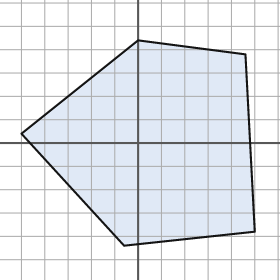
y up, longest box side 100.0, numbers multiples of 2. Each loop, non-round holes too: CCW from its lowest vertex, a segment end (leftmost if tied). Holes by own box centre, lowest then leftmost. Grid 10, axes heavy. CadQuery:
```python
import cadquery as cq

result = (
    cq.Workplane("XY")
    .moveTo(-6.0, -44.0)
    .lineTo(50.0, -38.0)
    .lineTo(46.0, 38.0)
    .lineTo(0.0, 44.0)
    .lineTo(-50.0, 4.0)
    .close()
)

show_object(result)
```